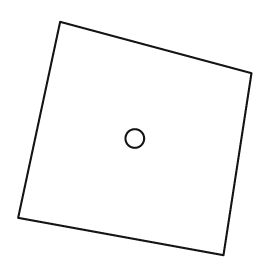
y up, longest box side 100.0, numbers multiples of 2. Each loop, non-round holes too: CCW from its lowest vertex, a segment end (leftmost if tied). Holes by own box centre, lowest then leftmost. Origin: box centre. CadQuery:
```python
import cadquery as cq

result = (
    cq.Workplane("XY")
    .moveTo(38.0, -50.0)
    .lineTo(50.0, 28.0)
    .lineTo(-32.0, 50.0)
    .lineTo(-50.0, -34.0)
    .close()
    .moveTo(0.0, 0.0)
    .circle(4.0)
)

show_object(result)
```